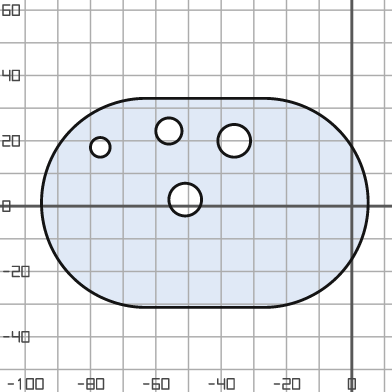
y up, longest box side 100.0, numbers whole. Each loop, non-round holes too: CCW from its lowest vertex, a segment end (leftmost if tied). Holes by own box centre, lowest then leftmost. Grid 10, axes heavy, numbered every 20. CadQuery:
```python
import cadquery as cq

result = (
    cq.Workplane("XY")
    .moveTo(-63.0, -31.0)
    .lineTo(-27.0, -31.0)
    .threePointArc((5.0, 1.0), (-27.0, 33.0))
    .lineTo(-63.0, 33.0)
    .threePointArc((-95.0, 1.0), (-63.0, -31.0))
    .close()
    .moveTo(-51.0, 2.0)
    .circle(5.0)
    .moveTo(-77.0, 18.0)
    .circle(3.0)
    .moveTo(-36.0, 20.0)
    .circle(5.0)
    .moveTo(-56.0, 23.0)
    .circle(4.0)
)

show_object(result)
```